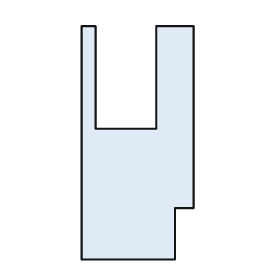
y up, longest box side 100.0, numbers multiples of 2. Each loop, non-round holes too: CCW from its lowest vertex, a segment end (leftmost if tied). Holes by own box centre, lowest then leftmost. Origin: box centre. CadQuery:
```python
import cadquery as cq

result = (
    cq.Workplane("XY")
    .moveTo(-24.0, -50.0)
    .lineTo(16.0, -50.0)
    .lineTo(16.0, -28.0)
    .lineTo(24.0, -28.0)
    .lineTo(24.0, 50.0)
    .lineTo(8.0, 50.0)
    .lineTo(8.0, 6.0)
    .lineTo(-18.0, 6.0)
    .lineTo(-18.0, 50.0)
    .lineTo(-24.0, 50.0)
    .close()
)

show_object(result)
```